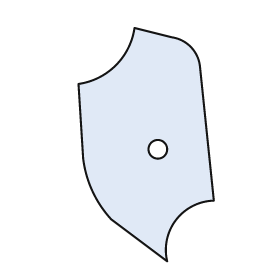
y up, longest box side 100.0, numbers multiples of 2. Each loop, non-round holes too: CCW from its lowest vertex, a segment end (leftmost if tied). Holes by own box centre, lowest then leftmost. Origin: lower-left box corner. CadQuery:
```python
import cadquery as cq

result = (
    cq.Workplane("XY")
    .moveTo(38.0, 0.0)
    .threePointArc((42.0, 18.0), (58.0, 26.0))
    .lineTo(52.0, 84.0)
    .threePointArc((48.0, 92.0), (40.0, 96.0))
    .lineTo(24.0, 100.0)
    .threePointArc((16.0, 84.0), (0.0, 76.0))
    .lineTo(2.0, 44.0)
    .threePointArc((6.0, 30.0), (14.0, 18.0))
    .close()
    .moveTo(34.0, 48.0)
    .circle(4.0)
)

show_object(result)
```